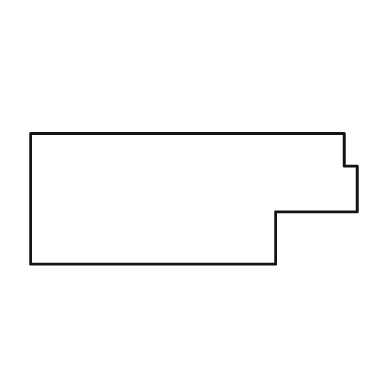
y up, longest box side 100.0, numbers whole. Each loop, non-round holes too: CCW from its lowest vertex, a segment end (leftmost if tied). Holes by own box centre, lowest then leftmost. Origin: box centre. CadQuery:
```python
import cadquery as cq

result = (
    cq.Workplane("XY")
    .moveTo(-50.0, -20.0)
    .lineTo(25.0, -20.0)
    .lineTo(25.0, -4.0)
    .lineTo(50.0, -4.0)
    .lineTo(50.0, 10.0)
    .lineTo(46.0, 10.0)
    .lineTo(46.0, 20.0)
    .lineTo(-50.0, 20.0)
    .close()
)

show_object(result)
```